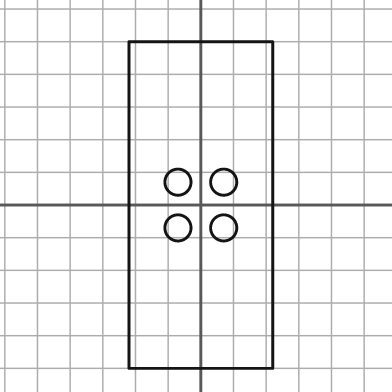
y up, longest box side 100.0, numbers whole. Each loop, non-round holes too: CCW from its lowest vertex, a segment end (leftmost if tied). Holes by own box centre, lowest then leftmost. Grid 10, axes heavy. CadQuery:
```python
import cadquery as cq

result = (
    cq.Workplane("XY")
    .moveTo(-22.0, -50.0)
    .lineTo(22.0, -50.0)
    .lineTo(22.0, 50.0)
    .lineTo(-22.0, 50.0)
    .close()
    .moveTo(-7.0, -7.0)
    .circle(4.0)
    .moveTo(7.0, -7.0)
    .circle(4.0)
    .moveTo(-7.0, 7.0)
    .circle(4.0)
    .moveTo(7.0, 7.0)
    .circle(4.0)
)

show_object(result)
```